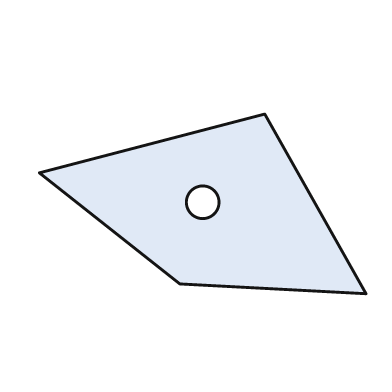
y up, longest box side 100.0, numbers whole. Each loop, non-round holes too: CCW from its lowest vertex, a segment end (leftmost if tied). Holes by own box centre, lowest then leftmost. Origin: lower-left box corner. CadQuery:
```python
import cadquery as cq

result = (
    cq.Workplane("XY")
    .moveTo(100.0, 0.0)
    .lineTo(69.0, 55.0)
    .lineTo(0.0, 37.0)
    .lineTo(43.0, 3.0)
    .close()
    .moveTo(50.0, 28.0)
    .circle(5.0)
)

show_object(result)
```